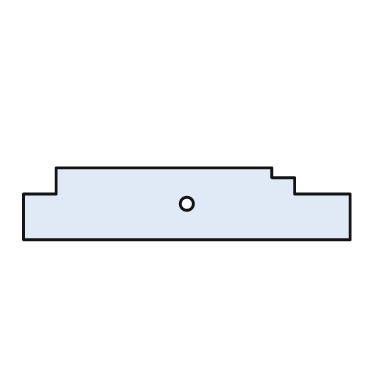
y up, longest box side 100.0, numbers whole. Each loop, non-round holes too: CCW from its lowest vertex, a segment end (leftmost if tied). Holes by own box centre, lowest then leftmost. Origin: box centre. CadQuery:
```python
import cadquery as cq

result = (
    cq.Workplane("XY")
    .moveTo(-50.0, -11.0)
    .lineTo(50.0, -11.0)
    .lineTo(50.0, 3.0)
    .lineTo(33.0, 3.0)
    .lineTo(33.0, 8.0)
    .lineTo(26.0, 8.0)
    .lineTo(26.0, 11.0)
    .lineTo(-40.0, 11.0)
    .lineTo(-40.0, 3.0)
    .lineTo(-50.0, 3.0)
    .close()
    .moveTo(0.0, 0.0)
    .circle(2.0)
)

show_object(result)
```